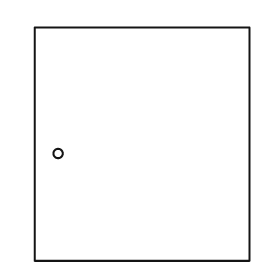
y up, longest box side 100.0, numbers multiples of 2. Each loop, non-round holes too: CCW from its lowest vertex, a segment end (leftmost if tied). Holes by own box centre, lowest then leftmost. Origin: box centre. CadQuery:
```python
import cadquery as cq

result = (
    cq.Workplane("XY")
    .moveTo(-46.0, -50.0)
    .lineTo(46.0, -50.0)
    .lineTo(46.0, 50.0)
    .lineTo(-46.0, 50.0)
    .close()
    .moveTo(-36.0, -4.0)
    .circle(2.0)
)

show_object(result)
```